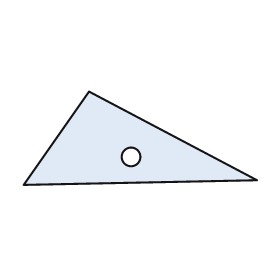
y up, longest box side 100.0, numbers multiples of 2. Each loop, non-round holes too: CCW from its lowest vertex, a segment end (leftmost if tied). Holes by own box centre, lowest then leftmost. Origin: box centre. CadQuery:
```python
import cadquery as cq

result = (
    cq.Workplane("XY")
    .moveTo(-50.0, -20.0)
    .lineTo(50.0, -18.0)
    .lineTo(-22.0, 20.0)
    .close()
    .moveTo(-4.0, -8.0)
    .circle(4.0)
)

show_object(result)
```